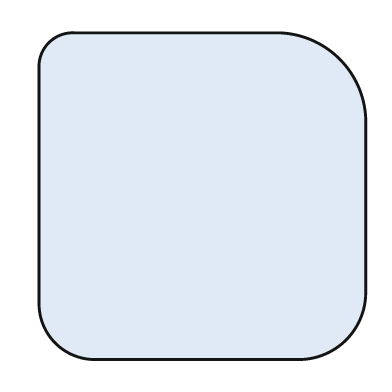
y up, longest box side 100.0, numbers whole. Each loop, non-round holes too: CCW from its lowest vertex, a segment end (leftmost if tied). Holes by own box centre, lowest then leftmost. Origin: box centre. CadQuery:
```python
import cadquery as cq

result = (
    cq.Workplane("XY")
    .moveTo(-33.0, -50.0)
    .lineTo(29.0, -50.0)
    .threePointArc((44.0, -44.0), (50.0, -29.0))
    .lineTo(50.0, 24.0)
    .threePointArc((42.0, 42.0), (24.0, 50.0))
    .lineTo(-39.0, 50.0)
    .threePointArc((-47.0, 47.0), (-50.0, 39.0))
    .lineTo(-50.0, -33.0)
    .threePointArc((-45.0, -45.0), (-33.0, -50.0))
    .close()
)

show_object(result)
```